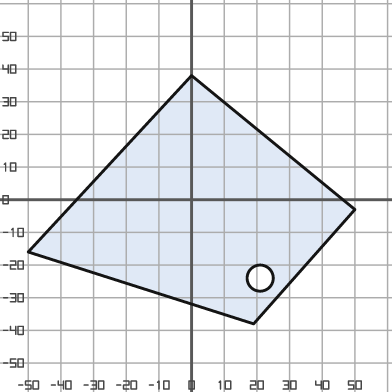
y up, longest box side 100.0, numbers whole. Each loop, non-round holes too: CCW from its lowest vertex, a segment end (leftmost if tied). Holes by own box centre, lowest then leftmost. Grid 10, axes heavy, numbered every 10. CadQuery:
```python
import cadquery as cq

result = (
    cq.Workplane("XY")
    .moveTo(19.0, -38.0)
    .lineTo(50.0, -3.0)
    .lineTo(0.0, 38.0)
    .lineTo(-50.0, -16.0)
    .close()
    .moveTo(21.0, -24.0)
    .circle(4.0)
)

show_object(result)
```